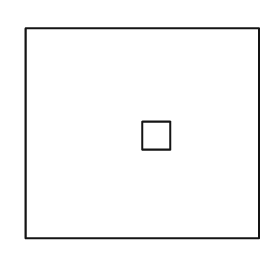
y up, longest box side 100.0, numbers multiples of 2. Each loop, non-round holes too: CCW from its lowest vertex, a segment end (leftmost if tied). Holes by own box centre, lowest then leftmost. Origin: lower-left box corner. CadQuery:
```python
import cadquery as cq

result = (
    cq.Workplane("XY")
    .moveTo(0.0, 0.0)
    .lineTo(100.0, 0.0)
    .lineTo(100.0, 90.0)
    .lineTo(0.0, 90.0)
    .close()
    .moveTo(50.0, 38.0)
    .lineTo(62.0, 38.0)
    .lineTo(62.0, 50.0)
    .lineTo(50.0, 50.0)
    .close()
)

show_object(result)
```